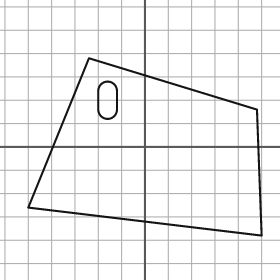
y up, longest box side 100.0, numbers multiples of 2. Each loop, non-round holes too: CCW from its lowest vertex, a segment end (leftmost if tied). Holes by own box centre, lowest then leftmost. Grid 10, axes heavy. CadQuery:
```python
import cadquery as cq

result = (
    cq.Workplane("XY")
    .moveTo(50.0, -38.0)
    .lineTo(48.0, 16.0)
    .lineTo(-24.0, 38.0)
    .lineTo(-50.0, -26.0)
    .close()
    .moveTo(-20.0, 16.0)
    .threePointArc((-16.0, 12.0), (-12.0, 16.0))
    .lineTo(-12.0, 24.0)
    .threePointArc((-16.0, 28.0), (-20.0, 24.0))
    .close()
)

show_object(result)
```